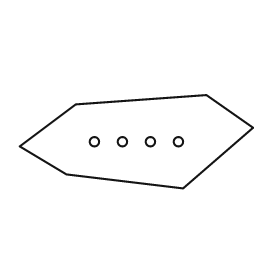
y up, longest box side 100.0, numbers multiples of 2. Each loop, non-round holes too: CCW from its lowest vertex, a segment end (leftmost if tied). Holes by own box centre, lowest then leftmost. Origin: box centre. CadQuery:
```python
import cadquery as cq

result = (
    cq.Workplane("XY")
    .moveTo(20.0, -20.0)
    .lineTo(50.0, 6.0)
    .lineTo(30.0, 20.0)
    .lineTo(-26.0, 16.0)
    .lineTo(-50.0, -2.0)
    .lineTo(-30.0, -14.0)
    .close()
    .moveTo(-18.0, 0.0)
    .circle(2.0)
    .moveTo(-6.0, 0.0)
    .circle(2.0)
    .moveTo(6.0, 0.0)
    .circle(2.0)
    .moveTo(18.0, 0.0)
    .circle(2.0)
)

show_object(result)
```